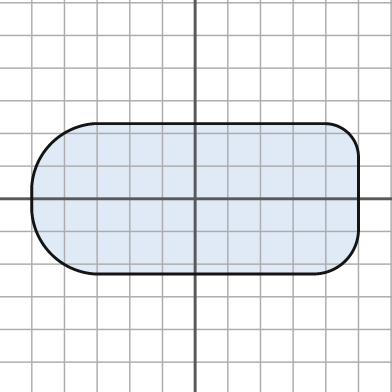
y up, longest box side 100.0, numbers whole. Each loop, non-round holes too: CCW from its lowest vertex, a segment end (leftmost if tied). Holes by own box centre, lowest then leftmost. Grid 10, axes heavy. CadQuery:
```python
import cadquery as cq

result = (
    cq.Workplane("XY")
    .moveTo(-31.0, -23.0)
    .lineTo(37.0, -23.0)
    .threePointArc((46.0, -19.0), (50.0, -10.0))
    .lineTo(50.0, 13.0)
    .threePointArc((47.0, 20.0), (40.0, 23.0))
    .lineTo(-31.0, 23.0)
    .threePointArc((-44.0, 17.0), (-50.0, 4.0))
    .lineTo(-50.0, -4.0)
    .threePointArc((-44.0, -17.0), (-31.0, -23.0))
    .close()
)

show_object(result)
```